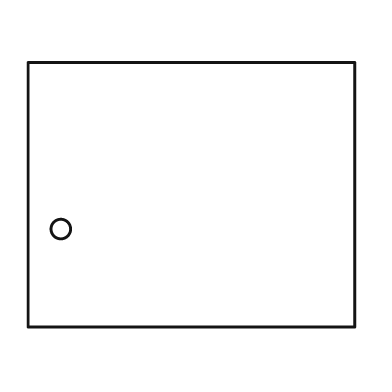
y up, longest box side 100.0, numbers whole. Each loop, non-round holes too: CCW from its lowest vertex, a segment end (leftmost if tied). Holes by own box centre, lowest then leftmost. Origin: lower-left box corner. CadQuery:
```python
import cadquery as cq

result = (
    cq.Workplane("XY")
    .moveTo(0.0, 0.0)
    .lineTo(100.0, 0.0)
    .lineTo(100.0, 81.0)
    .lineTo(0.0, 81.0)
    .close()
    .moveTo(10.0, 30.0)
    .circle(3.0)
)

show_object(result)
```